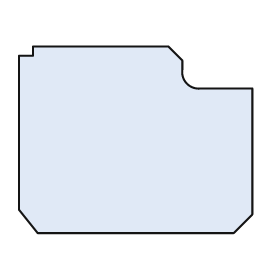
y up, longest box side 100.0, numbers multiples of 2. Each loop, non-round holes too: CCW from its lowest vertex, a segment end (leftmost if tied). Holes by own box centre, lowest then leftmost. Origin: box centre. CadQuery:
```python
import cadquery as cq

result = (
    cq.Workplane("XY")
    .moveTo(-42.0, -40.0)
    .lineTo(42.0, -40.0)
    .lineTo(50.0, -32.0)
    .lineTo(50.0, 22.0)
    .lineTo(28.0, 22.0)
    .threePointArc((22.0, 24.0), (20.0, 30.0))
    .lineTo(20.0, 34.0)
    .lineTo(14.0, 40.0)
    .lineTo(-44.0, 40.0)
    .lineTo(-44.0, 36.0)
    .lineTo(-50.0, 36.0)
    .lineTo(-50.0, -30.0)
    .close()
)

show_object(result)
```